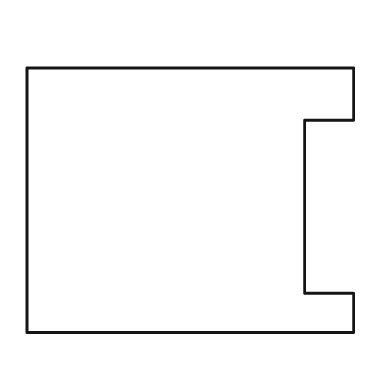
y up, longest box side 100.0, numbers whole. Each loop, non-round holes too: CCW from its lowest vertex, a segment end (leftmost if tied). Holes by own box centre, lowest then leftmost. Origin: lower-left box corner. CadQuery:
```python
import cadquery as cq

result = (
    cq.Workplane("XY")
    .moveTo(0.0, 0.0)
    .lineTo(100.0, 0.0)
    .lineTo(100.0, 12.0)
    .lineTo(85.0, 12.0)
    .lineTo(85.0, 65.0)
    .lineTo(100.0, 65.0)
    .lineTo(100.0, 81.0)
    .lineTo(0.0, 81.0)
    .close()
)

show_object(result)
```